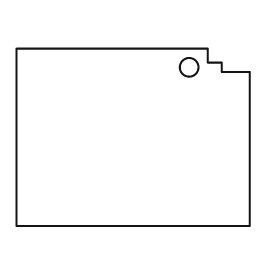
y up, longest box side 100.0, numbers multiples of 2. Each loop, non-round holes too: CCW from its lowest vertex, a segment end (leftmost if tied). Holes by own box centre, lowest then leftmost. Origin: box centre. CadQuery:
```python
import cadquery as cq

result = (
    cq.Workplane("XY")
    .moveTo(-50.0, -38.0)
    .lineTo(50.0, -38.0)
    .lineTo(50.0, 28.0)
    .lineTo(38.0, 28.0)
    .lineTo(38.0, 32.0)
    .lineTo(32.0, 32.0)
    .lineTo(32.0, 38.0)
    .lineTo(-50.0, 38.0)
    .close()
    .moveTo(24.0, 30.0)
    .circle(4.0)
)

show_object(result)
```